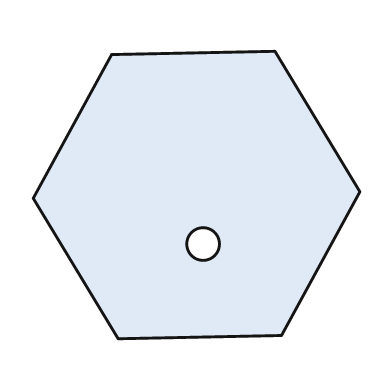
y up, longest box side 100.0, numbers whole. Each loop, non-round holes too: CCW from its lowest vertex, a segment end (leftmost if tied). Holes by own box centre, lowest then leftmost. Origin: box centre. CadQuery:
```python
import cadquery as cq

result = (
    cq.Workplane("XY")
    .moveTo(-24.0, -44.0)
    .lineTo(26.0, -43.0)
    .lineTo(50.0, 1.0)
    .lineTo(24.0, 44.0)
    .lineTo(-26.0, 43.0)
    .lineTo(-50.0, -1.0)
    .close()
    .moveTo(2.0, -15.0)
    .circle(5.0)
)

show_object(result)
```